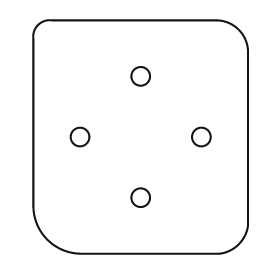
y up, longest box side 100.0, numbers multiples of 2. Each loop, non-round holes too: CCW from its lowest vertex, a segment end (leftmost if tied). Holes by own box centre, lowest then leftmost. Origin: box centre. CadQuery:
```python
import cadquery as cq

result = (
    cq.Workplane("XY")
    .moveTo(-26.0, -50.0)
    .lineTo(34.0, -50.0)
    .threePointArc((42.0, -46.0), (46.0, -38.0))
    .lineTo(46.0, 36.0)
    .threePointArc((42.0, 46.0), (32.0, 50.0))
    .lineTo(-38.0, 50.0)
    .threePointArc((-44.0, 48.0), (-46.0, 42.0))
    .lineTo(-46.0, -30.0)
    .threePointArc((-40.0, -44.0), (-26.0, -50.0))
    .close()
    .moveTo(0.0, -26.0)
    .circle(4.0)
    .moveTo(-26.0, 0.0)
    .circle(4.0)
    .moveTo(26.0, 0.0)
    .circle(4.0)
    .moveTo(0.0, 26.0)
    .circle(4.0)
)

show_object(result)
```